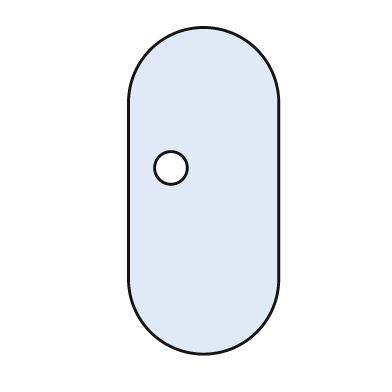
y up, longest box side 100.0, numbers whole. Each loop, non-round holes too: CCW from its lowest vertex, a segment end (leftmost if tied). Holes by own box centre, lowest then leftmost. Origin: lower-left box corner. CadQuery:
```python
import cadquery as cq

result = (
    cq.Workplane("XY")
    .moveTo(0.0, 23.0)
    .threePointArc((23.0, 0.0), (46.0, 23.0))
    .lineTo(46.0, 77.0)
    .threePointArc((23.0, 100.0), (0.0, 77.0))
    .close()
    .moveTo(13.0, 57.0)
    .circle(5.0)
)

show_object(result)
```